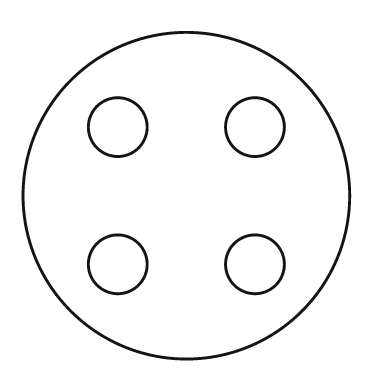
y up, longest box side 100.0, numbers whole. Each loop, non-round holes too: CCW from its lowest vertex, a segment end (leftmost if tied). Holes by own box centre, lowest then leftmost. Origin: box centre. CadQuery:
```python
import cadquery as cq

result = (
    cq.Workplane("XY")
    .moveTo(0.0, 0.0)
    .circle(50.0)
    .moveTo(-21.0, -21.0)
    .circle(9.0)
    .moveTo(21.0, -21.0)
    .circle(9.0)
    .moveTo(-21.0, 21.0)
    .circle(9.0)
    .moveTo(21.0, 21.0)
    .circle(9.0)
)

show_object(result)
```